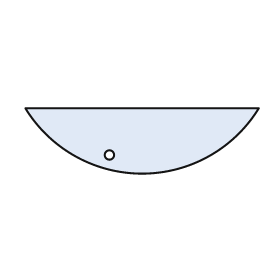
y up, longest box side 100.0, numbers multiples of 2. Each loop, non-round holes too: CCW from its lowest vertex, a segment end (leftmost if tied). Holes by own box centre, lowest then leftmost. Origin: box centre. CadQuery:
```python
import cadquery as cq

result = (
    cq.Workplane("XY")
    .moveTo(-50.0, 14.0)
    .threePointArc((0.0, -14.0), (50.0, 14.0))
    .close()
    .moveTo(-14.0, -6.0)
    .circle(2.0)
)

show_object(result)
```